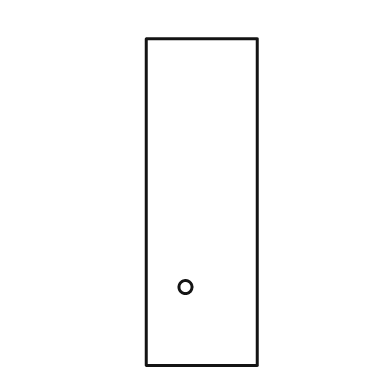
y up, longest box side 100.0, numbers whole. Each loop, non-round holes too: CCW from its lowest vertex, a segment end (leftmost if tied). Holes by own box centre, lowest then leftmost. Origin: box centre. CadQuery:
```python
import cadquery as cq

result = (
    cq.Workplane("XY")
    .moveTo(-17.0, -50.0)
    .lineTo(17.0, -50.0)
    .lineTo(17.0, 50.0)
    .lineTo(-17.0, 50.0)
    .close()
    .moveTo(-5.0, -26.0)
    .circle(2.0)
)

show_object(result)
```